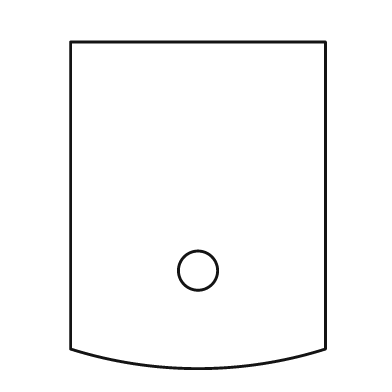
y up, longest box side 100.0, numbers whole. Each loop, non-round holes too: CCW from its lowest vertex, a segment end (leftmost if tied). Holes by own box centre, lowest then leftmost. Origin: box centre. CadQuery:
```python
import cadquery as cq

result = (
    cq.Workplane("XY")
    .moveTo(-39.0, -44.0)
    .threePointArc((0.0, -50.0), (39.0, -44.0))
    .lineTo(39.0, 50.0)
    .lineTo(-39.0, 50.0)
    .close()
    .moveTo(0.0, -20.0)
    .circle(6.0)
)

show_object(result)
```